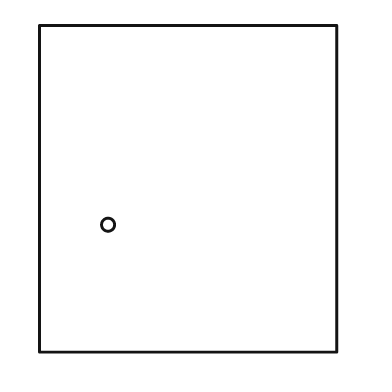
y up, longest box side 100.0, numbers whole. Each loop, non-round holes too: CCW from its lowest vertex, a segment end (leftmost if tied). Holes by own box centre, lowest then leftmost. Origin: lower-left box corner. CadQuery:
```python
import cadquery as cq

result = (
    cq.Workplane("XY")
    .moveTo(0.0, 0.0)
    .lineTo(91.0, 0.0)
    .lineTo(91.0, 100.0)
    .lineTo(0.0, 100.0)
    .close()
    .moveTo(21.0, 39.0)
    .circle(2.0)
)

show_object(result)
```